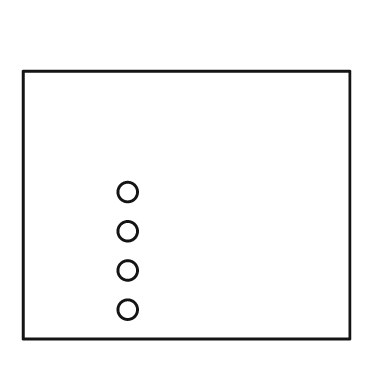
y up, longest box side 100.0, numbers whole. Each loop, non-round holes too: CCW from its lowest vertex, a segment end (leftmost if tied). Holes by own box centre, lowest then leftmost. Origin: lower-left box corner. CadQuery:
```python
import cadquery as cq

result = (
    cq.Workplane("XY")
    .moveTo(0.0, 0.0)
    .lineTo(100.0, 0.0)
    .lineTo(100.0, 82.0)
    .lineTo(0.0, 82.0)
    .close()
    .moveTo(32.0, 9.0)
    .circle(3.0)
    .moveTo(32.0, 21.0)
    .circle(3.0)
    .moveTo(32.0, 33.0)
    .circle(3.0)
    .moveTo(32.0, 45.0)
    .circle(3.0)
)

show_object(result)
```